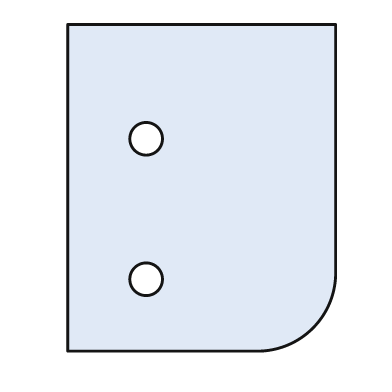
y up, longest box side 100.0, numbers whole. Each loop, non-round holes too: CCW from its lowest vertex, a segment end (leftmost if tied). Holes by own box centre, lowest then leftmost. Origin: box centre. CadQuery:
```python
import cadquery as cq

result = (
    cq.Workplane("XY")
    .moveTo(-41.0, -50.0)
    .lineTo(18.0, -50.0)
    .threePointArc((34.0, -43.0), (41.0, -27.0))
    .lineTo(41.0, 50.0)
    .lineTo(-41.0, 50.0)
    .close()
    .moveTo(-17.0, -28.0)
    .circle(5.0)
    .moveTo(-17.0, 15.0)
    .circle(5.0)
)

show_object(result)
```